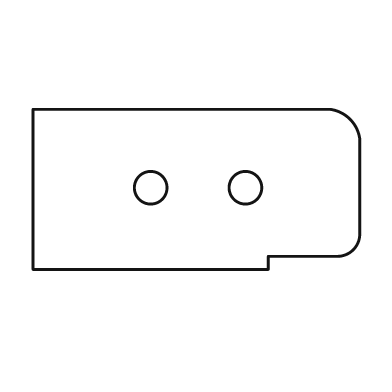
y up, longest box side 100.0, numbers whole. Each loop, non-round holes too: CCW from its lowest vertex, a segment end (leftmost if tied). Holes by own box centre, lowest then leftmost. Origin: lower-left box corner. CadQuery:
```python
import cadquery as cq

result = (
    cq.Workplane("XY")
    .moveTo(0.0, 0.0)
    .lineTo(72.0, 0.0)
    .lineTo(72.0, 4.0)
    .lineTo(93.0, 4.0)
    .threePointArc((98.0, 6.0), (100.0, 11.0))
    .lineTo(100.0, 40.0)
    .threePointArc((97.0, 46.0), (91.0, 49.0))
    .lineTo(0.0, 49.0)
    .close()
    .moveTo(36.0, 25.0)
    .circle(5.0)
    .moveTo(65.0, 25.0)
    .circle(5.0)
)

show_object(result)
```